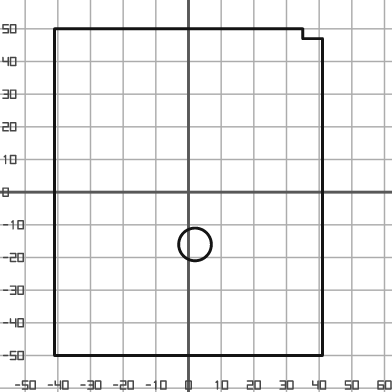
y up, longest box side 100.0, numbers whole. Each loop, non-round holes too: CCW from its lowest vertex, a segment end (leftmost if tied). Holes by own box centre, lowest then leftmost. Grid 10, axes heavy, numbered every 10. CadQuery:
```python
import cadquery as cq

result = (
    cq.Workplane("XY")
    .moveTo(-41.0, -50.0)
    .lineTo(41.0, -50.0)
    .lineTo(41.0, 47.0)
    .lineTo(35.0, 47.0)
    .lineTo(35.0, 50.0)
    .lineTo(-41.0, 50.0)
    .close()
    .moveTo(2.0, -16.0)
    .circle(5.0)
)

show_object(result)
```